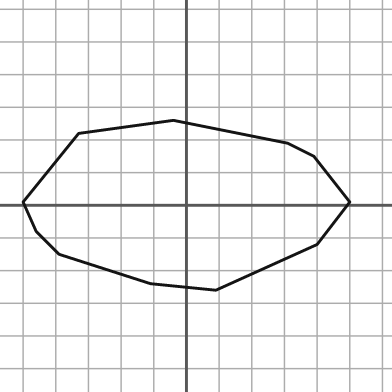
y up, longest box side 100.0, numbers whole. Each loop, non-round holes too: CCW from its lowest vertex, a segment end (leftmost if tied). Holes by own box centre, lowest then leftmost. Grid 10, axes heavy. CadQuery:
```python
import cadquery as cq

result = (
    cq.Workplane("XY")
    .moveTo(9.0, -26.0)
    .lineTo(40.0, -12.0)
    .lineTo(50.0, 1.0)
    .lineTo(39.0, 15.0)
    .lineTo(31.0, 19.0)
    .lineTo(-4.0, 26.0)
    .lineTo(-33.0, 22.0)
    .lineTo(-50.0, 1.0)
    .lineTo(-46.0, -8.0)
    .lineTo(-39.0, -15.0)
    .lineTo(-11.0, -24.0)
    .close()
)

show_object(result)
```